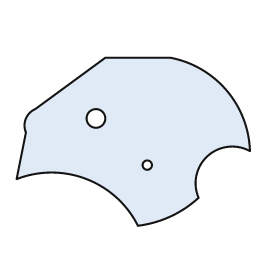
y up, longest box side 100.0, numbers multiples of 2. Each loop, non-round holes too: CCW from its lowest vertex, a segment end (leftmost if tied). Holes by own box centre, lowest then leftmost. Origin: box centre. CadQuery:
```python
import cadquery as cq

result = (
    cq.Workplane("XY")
    .moveTo(2.0, -36.0)
    .threePointArc((16.0, -32.0), (28.0, -24.0))
    .threePointArc((32.0, -6.0), (50.0, -4.0))
    .threePointArc((40.0, 22.0), (16.0, 36.0))
    .lineTo(-12.0, 36.0)
    .lineTo(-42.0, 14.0)
    .threePointArc((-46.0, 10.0), (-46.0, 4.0))
    .lineTo(-50.0, -16.0)
    .threePointArc((-20.0, -16.0), (2.0, -36.0))
    .close()
    .moveTo(6.0, -10.0)
    .circle(2.0)
    .moveTo(-16.0, 10.0)
    .circle(4.0)
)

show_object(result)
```